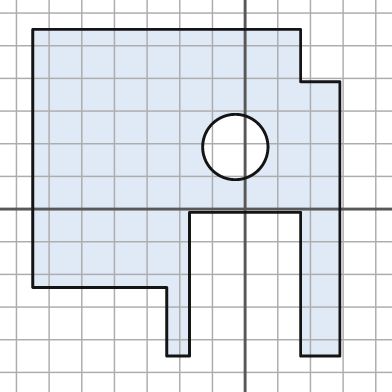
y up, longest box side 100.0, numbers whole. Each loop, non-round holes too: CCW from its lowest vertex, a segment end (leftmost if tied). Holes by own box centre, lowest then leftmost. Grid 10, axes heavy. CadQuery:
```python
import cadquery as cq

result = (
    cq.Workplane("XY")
    .moveTo(-24.0, -45.0)
    .lineTo(-17.0, -45.0)
    .lineTo(-17.0, -1.0)
    .lineTo(17.0, -1.0)
    .lineTo(17.0, -45.0)
    .lineTo(29.0, -45.0)
    .lineTo(29.0, 39.0)
    .lineTo(17.0, 39.0)
    .lineTo(17.0, 55.0)
    .lineTo(-65.0, 55.0)
    .lineTo(-65.0, -24.0)
    .lineTo(-24.0, -24.0)
    .close()
    .moveTo(-3.0, 19.0)
    .circle(10.0)
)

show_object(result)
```